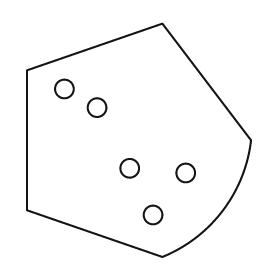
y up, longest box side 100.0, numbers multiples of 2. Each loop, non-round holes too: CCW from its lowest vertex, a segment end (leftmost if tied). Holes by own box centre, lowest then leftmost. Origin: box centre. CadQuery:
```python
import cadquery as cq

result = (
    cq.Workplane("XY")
    .moveTo(10.0, -50.0)
    .threePointArc((36.0, -30.0), (48.0, 0.0))
    .lineTo(10.0, 50.0)
    .lineTo(-48.0, 30.0)
    .lineTo(-48.0, -30.0)
    .close()
    .moveTo(6.0, -32.0)
    .circle(4.0)
    .moveTo(20.0, -14.0)
    .circle(4.0)
    .moveTo(-4.0, -12.0)
    .circle(4.0)
    .moveTo(-18.0, 14.0)
    .circle(4.0)
    .moveTo(-32.0, 22.0)
    .circle(4.0)
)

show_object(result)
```